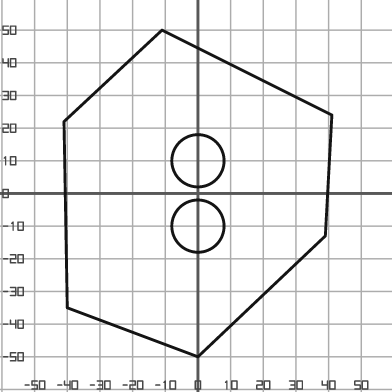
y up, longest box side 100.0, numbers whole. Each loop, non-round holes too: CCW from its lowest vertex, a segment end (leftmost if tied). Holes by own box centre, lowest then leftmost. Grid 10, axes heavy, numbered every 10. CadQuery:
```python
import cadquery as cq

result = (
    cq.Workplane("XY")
    .moveTo(0.0, -50.0)
    .lineTo(39.0, -13.0)
    .lineTo(41.0, 24.0)
    .lineTo(-11.0, 50.0)
    .lineTo(-41.0, 22.0)
    .lineTo(-40.0, -35.0)
    .close()
    .moveTo(0.0, -10.0)
    .circle(8.0)
    .moveTo(0.0, 10.0)
    .circle(8.0)
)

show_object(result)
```